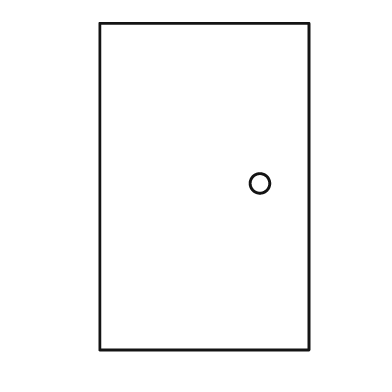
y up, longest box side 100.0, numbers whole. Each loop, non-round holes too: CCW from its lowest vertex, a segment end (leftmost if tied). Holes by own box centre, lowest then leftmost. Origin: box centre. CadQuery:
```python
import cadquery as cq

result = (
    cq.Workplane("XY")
    .moveTo(-32.0, -50.0)
    .lineTo(32.0, -50.0)
    .lineTo(32.0, 50.0)
    .lineTo(-32.0, 50.0)
    .close()
    .moveTo(17.0, 1.0)
    .circle(3.0)
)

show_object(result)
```